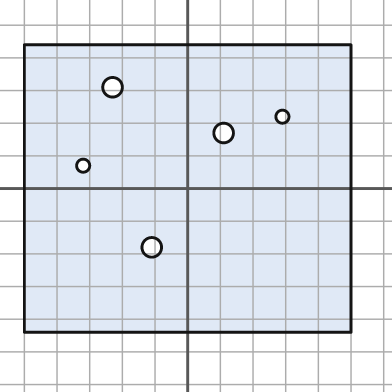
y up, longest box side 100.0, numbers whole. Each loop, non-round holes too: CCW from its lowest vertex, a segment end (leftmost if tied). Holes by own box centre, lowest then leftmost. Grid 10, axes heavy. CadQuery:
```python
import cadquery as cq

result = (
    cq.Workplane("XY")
    .moveTo(-50.0, -44.0)
    .lineTo(50.0, -44.0)
    .lineTo(50.0, 44.0)
    .lineTo(-50.0, 44.0)
    .close()
    .moveTo(-11.0, -18.0)
    .circle(3.0)
    .moveTo(-32.0, 7.0)
    .circle(2.0)
    .moveTo(11.0, 17.0)
    .circle(3.0)
    .moveTo(29.0, 22.0)
    .circle(2.0)
    .moveTo(-23.0, 31.0)
    .circle(3.0)
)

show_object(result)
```